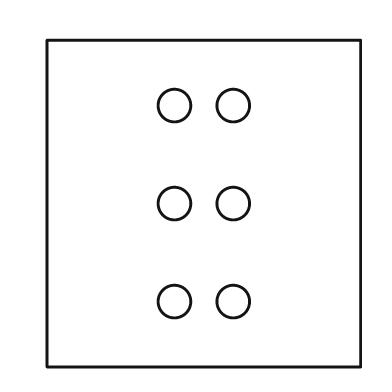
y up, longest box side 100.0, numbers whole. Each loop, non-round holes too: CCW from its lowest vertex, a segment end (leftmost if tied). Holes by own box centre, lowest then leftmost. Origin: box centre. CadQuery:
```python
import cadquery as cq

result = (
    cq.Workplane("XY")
    .moveTo(-48.0, -50.0)
    .lineTo(48.0, -50.0)
    .lineTo(48.0, 50.0)
    .lineTo(-48.0, 50.0)
    .close()
    .moveTo(-9.0, -30.0)
    .circle(5.0)
    .moveTo(9.0, -30.0)
    .circle(5.0)
    .moveTo(-9.0, 0.0)
    .circle(5.0)
    .moveTo(9.0, 0.0)
    .circle(5.0)
    .moveTo(-9.0, 30.0)
    .circle(5.0)
    .moveTo(9.0, 30.0)
    .circle(5.0)
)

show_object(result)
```